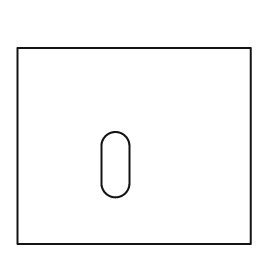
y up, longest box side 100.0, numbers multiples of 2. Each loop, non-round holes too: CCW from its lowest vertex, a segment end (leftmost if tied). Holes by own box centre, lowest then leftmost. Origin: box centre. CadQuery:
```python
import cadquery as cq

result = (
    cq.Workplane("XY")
    .moveTo(-50.0, -42.0)
    .lineTo(50.0, -42.0)
    .lineTo(50.0, 42.0)
    .lineTo(-50.0, 42.0)
    .close()
    .moveTo(-14.0, -16.0)
    .threePointArc((-8.0, -22.0), (-2.0, -16.0))
    .lineTo(-2.0, 0.0)
    .threePointArc((-8.0, 6.0), (-14.0, 0.0))
    .close()
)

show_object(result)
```